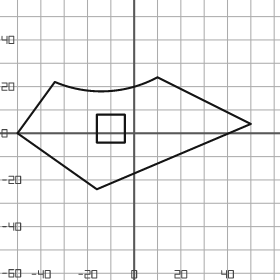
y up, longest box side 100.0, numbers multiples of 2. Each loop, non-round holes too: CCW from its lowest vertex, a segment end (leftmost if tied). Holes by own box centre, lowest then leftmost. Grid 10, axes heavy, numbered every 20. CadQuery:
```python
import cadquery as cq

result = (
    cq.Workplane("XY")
    .moveTo(-16.0, -24.0)
    .lineTo(50.0, 4.0)
    .lineTo(10.0, 24.0)
    .threePointArc((-12.0, 18.0), (-34.0, 22.0))
    .lineTo(-50.0, 0.0)
    .close()
    .moveTo(-16.0, -4.0)
    .lineTo(-4.0, -4.0)
    .lineTo(-4.0, 8.0)
    .lineTo(-16.0, 8.0)
    .close()
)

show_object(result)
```